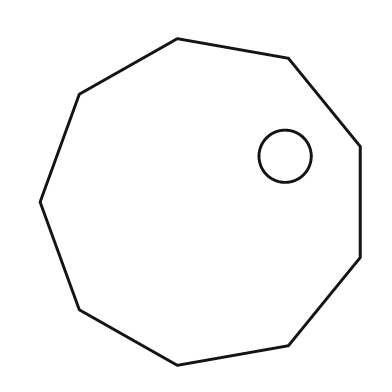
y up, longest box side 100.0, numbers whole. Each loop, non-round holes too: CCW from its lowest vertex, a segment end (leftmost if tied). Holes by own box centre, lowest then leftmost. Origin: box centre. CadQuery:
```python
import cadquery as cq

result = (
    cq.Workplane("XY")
    .moveTo(-7.0, -50.0)
    .lineTo(27.0, -44.0)
    .lineTo(49.0, -17.0)
    .lineTo(49.0, 17.0)
    .lineTo(27.0, 44.0)
    .lineTo(-7.0, 50.0)
    .lineTo(-37.0, 33.0)
    .lineTo(-49.0, 0.0)
    .lineTo(-37.0, -33.0)
    .close()
    .moveTo(26.0, 14.0)
    .circle(8.0)
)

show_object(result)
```